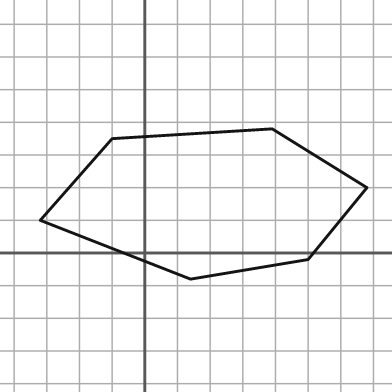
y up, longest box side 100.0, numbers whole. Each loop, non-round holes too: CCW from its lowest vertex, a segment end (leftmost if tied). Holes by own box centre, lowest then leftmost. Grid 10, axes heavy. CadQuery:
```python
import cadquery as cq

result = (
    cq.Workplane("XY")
    .moveTo(14.0, -8.0)
    .lineTo(50.0, -2.0)
    .lineTo(68.0, 20.0)
    .lineTo(39.0, 38.0)
    .lineTo(-10.0, 35.0)
    .lineTo(-32.0, 10.0)
    .close()
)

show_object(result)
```